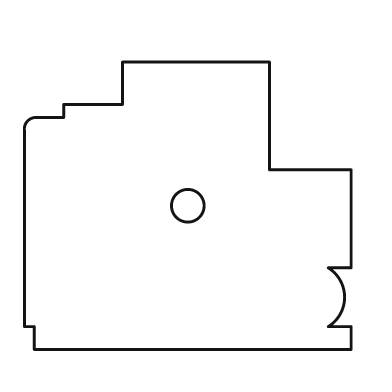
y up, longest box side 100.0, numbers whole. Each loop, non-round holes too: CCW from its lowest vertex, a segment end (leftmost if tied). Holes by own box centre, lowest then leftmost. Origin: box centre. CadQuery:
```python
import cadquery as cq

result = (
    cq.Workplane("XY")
    .moveTo(-47.0, -44.0)
    .lineTo(50.0, -44.0)
    .lineTo(50.0, -37.0)
    .lineTo(43.0, -37.0)
    .threePointArc((48.0, -28.0), (43.0, -19.0))
    .lineTo(50.0, -19.0)
    .lineTo(50.0, 11.0)
    .lineTo(25.0, 11.0)
    .lineTo(25.0, 44.0)
    .lineTo(-20.0, 44.0)
    .lineTo(-20.0, 31.0)
    .lineTo(-38.0, 31.0)
    .lineTo(-38.0, 27.0)
    .lineTo(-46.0, 27.0)
    .threePointArc((-49.0, 26.0), (-50.0, 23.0))
    .lineTo(-50.0, -37.0)
    .lineTo(-47.0, -37.0)
    .close()
    .moveTo(0.0, 0.0)
    .circle(5.0)
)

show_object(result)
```